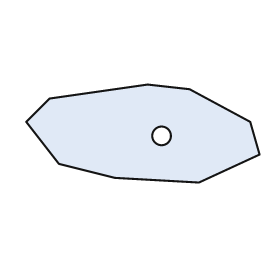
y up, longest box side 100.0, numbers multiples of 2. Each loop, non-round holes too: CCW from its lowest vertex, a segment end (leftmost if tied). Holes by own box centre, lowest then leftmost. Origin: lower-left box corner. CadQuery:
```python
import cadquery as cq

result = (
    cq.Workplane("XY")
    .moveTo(74.0, 0.0)
    .lineTo(100.0, 12.0)
    .lineTo(96.0, 26.0)
    .lineTo(70.0, 40.0)
    .lineTo(52.0, 42.0)
    .lineTo(10.0, 36.0)
    .lineTo(0.0, 26.0)
    .lineTo(14.0, 8.0)
    .lineTo(38.0, 2.0)
    .close()
    .moveTo(58.0, 20.0)
    .circle(4.0)
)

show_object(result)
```